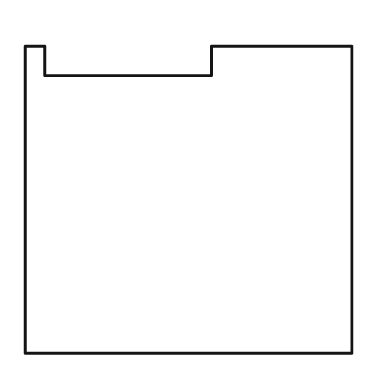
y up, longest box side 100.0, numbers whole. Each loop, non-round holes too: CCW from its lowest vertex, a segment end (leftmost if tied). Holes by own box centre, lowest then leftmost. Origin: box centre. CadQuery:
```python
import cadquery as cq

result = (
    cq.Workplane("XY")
    .moveTo(-50.0, -47.0)
    .lineTo(50.0, -47.0)
    .lineTo(50.0, 47.0)
    .lineTo(7.0, 47.0)
    .lineTo(7.0, 38.0)
    .lineTo(-44.0, 38.0)
    .lineTo(-44.0, 47.0)
    .lineTo(-50.0, 47.0)
    .close()
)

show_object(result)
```